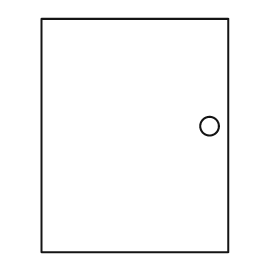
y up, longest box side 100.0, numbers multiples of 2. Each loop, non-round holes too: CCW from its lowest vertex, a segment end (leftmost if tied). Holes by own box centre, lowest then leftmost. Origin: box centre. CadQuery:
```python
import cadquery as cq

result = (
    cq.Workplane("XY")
    .moveTo(-40.0, -50.0)
    .lineTo(40.0, -50.0)
    .lineTo(40.0, 50.0)
    .lineTo(-40.0, 50.0)
    .close()
    .moveTo(32.0, 4.0)
    .circle(4.0)
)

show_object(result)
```